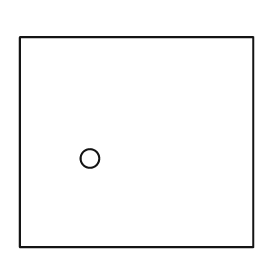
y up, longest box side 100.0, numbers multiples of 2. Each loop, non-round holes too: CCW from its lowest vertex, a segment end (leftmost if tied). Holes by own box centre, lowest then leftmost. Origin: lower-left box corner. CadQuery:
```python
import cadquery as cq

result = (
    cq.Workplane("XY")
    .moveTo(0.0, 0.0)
    .lineTo(100.0, 0.0)
    .lineTo(100.0, 90.0)
    .lineTo(0.0, 90.0)
    .close()
    .moveTo(30.0, 38.0)
    .circle(4.0)
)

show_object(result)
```